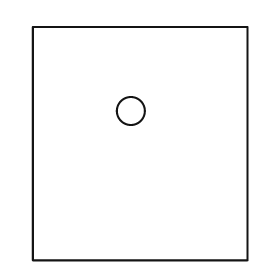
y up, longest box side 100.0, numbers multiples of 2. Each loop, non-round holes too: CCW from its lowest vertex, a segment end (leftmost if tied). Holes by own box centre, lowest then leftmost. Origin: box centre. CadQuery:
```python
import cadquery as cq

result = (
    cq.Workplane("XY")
    .moveTo(-46.0, -50.0)
    .lineTo(46.0, -50.0)
    .lineTo(46.0, 50.0)
    .lineTo(-46.0, 50.0)
    .close()
    .moveTo(-4.0, 14.0)
    .circle(6.0)
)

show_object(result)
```